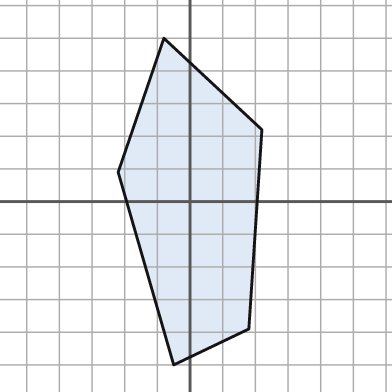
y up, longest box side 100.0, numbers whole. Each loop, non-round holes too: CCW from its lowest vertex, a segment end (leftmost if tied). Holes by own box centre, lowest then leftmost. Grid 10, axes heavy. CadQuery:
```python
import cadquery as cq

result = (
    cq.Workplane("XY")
    .moveTo(-5.0, -50.0)
    .lineTo(18.0, -39.0)
    .lineTo(22.0, 22.0)
    .lineTo(-8.0, 50.0)
    .lineTo(-22.0, 9.0)
    .close()
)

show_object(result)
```